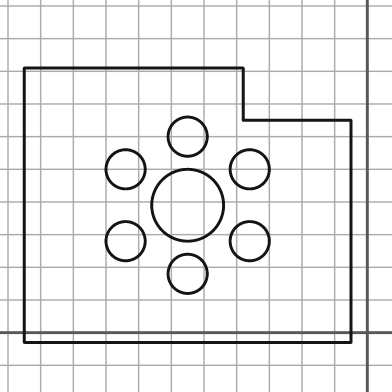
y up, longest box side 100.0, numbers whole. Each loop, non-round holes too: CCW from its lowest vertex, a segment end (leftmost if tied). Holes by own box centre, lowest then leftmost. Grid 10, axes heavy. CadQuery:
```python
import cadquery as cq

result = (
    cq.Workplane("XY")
    .moveTo(-105.0, -3.0)
    .lineTo(-5.0, -3.0)
    .lineTo(-5.0, 65.0)
    .lineTo(-38.0, 65.0)
    .lineTo(-38.0, 81.0)
    .lineTo(-105.0, 81.0)
    .close()
    .moveTo(-55.0, 18.0)
    .circle(6.0)
    .moveTo(-74.0, 28.0)
    .circle(6.0)
    .moveTo(-36.0, 28.0)
    .circle(6.0)
    .moveTo(-55.0, 39.0)
    .circle(11.0)
    .moveTo(-74.0, 50.0)
    .circle(6.0)
    .moveTo(-36.0, 50.0)
    .circle(6.0)
    .moveTo(-55.0, 60.0)
    .circle(6.0)
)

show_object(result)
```